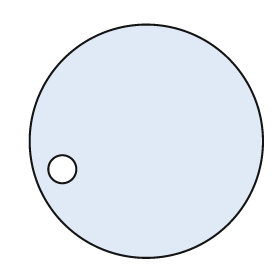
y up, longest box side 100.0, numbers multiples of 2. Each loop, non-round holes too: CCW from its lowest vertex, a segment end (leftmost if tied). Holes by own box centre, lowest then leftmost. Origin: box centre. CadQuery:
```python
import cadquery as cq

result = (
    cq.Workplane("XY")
    .moveTo(0.0, 0.0)
    .circle(50.0)
    .moveTo(-36.0, -12.0)
    .circle(6.0)
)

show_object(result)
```